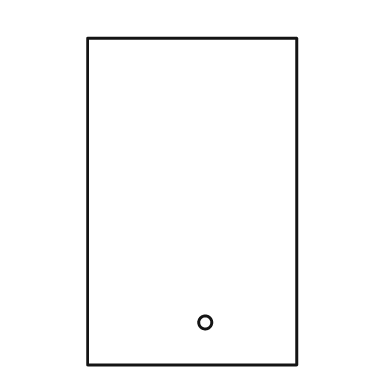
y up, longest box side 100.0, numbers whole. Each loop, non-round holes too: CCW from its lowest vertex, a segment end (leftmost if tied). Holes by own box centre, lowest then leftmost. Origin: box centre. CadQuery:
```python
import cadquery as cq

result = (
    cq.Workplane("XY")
    .moveTo(-32.0, -50.0)
    .lineTo(32.0, -50.0)
    .lineTo(32.0, 50.0)
    .lineTo(-32.0, 50.0)
    .close()
    .moveTo(4.0, -37.0)
    .circle(2.0)
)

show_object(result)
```